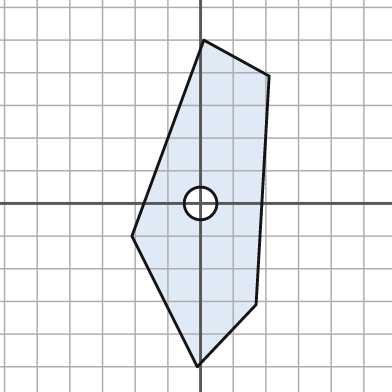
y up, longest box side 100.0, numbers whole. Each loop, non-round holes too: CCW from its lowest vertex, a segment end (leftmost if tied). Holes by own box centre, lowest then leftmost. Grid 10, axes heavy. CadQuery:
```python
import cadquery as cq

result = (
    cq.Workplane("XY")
    .moveTo(-1.0, -50.0)
    .lineTo(17.0, -31.0)
    .lineTo(21.0, 39.0)
    .lineTo(1.0, 50.0)
    .lineTo(-21.0, -10.0)
    .close()
    .moveTo(0.0, 0.0)
    .circle(5.0)
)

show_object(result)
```